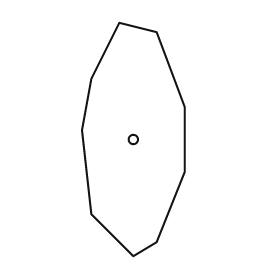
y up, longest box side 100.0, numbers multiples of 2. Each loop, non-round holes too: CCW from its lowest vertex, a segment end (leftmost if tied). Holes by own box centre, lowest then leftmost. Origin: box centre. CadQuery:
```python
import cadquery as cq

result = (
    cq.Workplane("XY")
    .moveTo(0.0, -50.0)
    .lineTo(10.0, -44.0)
    .lineTo(22.0, -14.0)
    .lineTo(22.0, 14.0)
    .lineTo(10.0, 46.0)
    .lineTo(-6.0, 50.0)
    .lineTo(-18.0, 26.0)
    .lineTo(-22.0, 4.0)
    .lineTo(-18.0, -32.0)
    .close()
    .moveTo(0.0, 0.0)
    .circle(2.0)
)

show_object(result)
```